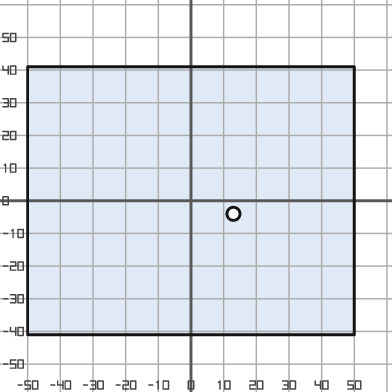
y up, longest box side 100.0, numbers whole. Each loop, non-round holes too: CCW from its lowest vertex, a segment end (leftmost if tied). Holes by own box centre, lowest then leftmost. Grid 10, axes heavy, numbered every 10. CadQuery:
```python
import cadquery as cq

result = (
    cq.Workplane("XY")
    .moveTo(-50.0, -41.0)
    .lineTo(50.0, -41.0)
    .lineTo(50.0, 41.0)
    .lineTo(-50.0, 41.0)
    .close()
    .moveTo(13.0, -4.0)
    .circle(2.0)
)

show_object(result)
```